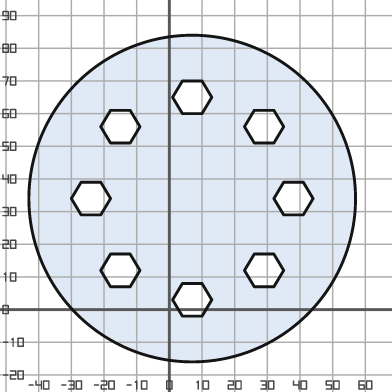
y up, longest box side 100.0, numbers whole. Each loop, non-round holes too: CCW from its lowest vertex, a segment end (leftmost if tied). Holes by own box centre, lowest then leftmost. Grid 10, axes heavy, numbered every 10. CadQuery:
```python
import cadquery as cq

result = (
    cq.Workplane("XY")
    .moveTo(7.0, 34.0)
    .circle(50.0)
    .moveTo(4.0, -2.0)
    .lineTo(10.0, -2.0)
    .lineTo(13.0, 3.0)
    .lineTo(10.0, 8.0)
    .lineTo(4.0, 8.0)
    .lineTo(1.0, 3.0)
    .close()
    .moveTo(-18.0, 7.0)
    .lineTo(-12.0, 7.0)
    .lineTo(-9.0, 12.0)
    .lineTo(-12.0, 17.0)
    .lineTo(-18.0, 17.0)
    .lineTo(-21.0, 12.0)
    .close()
    .moveTo(26.0, 7.0)
    .lineTo(32.0, 7.0)
    .lineTo(35.0, 12.0)
    .lineTo(32.0, 17.0)
    .lineTo(26.0, 17.0)
    .lineTo(23.0, 12.0)
    .close()
    .moveTo(-27.0, 29.0)
    .lineTo(-21.0, 29.0)
    .lineTo(-18.0, 34.0)
    .lineTo(-21.0, 39.0)
    .lineTo(-27.0, 39.0)
    .lineTo(-30.0, 34.0)
    .close()
    .moveTo(35.0, 29.0)
    .lineTo(41.0, 29.0)
    .lineTo(44.0, 34.0)
    .lineTo(41.0, 39.0)
    .lineTo(35.0, 39.0)
    .lineTo(32.0, 34.0)
    .close()
    .moveTo(-18.0, 51.0)
    .lineTo(-12.0, 51.0)
    .lineTo(-9.0, 56.0)
    .lineTo(-12.0, 61.0)
    .lineTo(-18.0, 61.0)
    .lineTo(-21.0, 56.0)
    .close()
    .moveTo(26.0, 51.0)
    .lineTo(32.0, 51.0)
    .lineTo(35.0, 56.0)
    .lineTo(32.0, 61.0)
    .lineTo(26.0, 61.0)
    .lineTo(23.0, 56.0)
    .close()
    .moveTo(4.0, 60.0)
    .lineTo(10.0, 60.0)
    .lineTo(13.0, 65.0)
    .lineTo(10.0, 70.0)
    .lineTo(4.0, 70.0)
    .lineTo(1.0, 65.0)
    .close()
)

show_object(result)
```